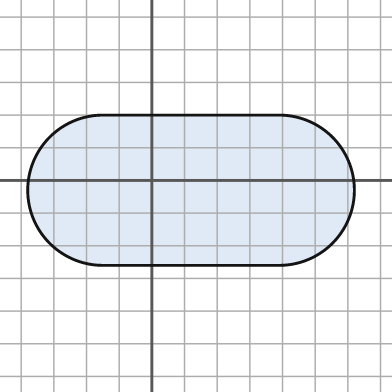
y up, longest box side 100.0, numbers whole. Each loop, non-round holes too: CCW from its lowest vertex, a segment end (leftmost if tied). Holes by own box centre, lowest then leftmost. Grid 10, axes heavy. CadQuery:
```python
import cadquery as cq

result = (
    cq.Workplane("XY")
    .moveTo(-15.0, -26.0)
    .lineTo(39.0, -26.0)
    .threePointArc((62.0, -3.0), (39.0, 20.0))
    .lineTo(-15.0, 20.0)
    .threePointArc((-38.0, -3.0), (-15.0, -26.0))
    .close()
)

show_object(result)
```